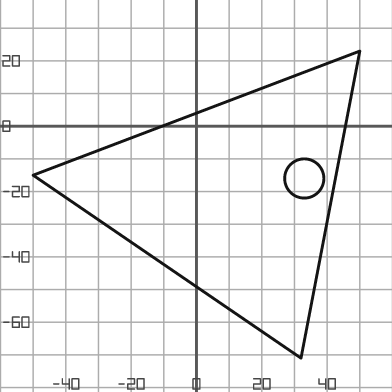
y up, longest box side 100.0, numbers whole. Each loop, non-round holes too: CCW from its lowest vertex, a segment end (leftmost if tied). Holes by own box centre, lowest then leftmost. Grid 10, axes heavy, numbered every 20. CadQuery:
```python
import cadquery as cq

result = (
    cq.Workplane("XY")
    .moveTo(32.0, -71.0)
    .lineTo(50.0, 23.0)
    .lineTo(-50.0, -15.0)
    .close()
    .moveTo(33.0, -16.0)
    .circle(6.0)
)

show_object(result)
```